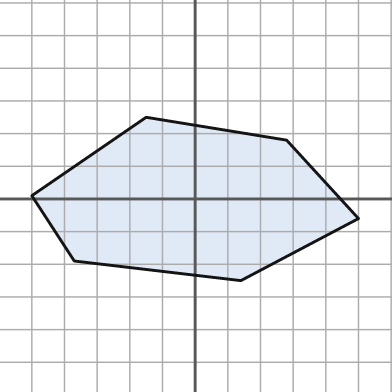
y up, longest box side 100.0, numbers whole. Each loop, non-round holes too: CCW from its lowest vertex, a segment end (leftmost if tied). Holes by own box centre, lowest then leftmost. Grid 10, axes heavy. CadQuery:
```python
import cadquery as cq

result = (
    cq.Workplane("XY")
    .moveTo(14.0, -25.0)
    .lineTo(50.0, -6.0)
    .lineTo(28.0, 18.0)
    .lineTo(-15.0, 25.0)
    .lineTo(-50.0, 1.0)
    .lineTo(-37.0, -19.0)
    .close()
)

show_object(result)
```